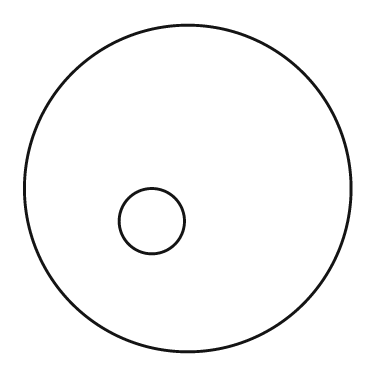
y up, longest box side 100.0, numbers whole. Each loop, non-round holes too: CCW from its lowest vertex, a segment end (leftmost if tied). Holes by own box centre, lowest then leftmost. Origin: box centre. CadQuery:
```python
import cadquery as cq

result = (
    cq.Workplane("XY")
    .moveTo(0.0, 0.0)
    .circle(50.0)
    .moveTo(-11.0, -10.0)
    .circle(10.0)
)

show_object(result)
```